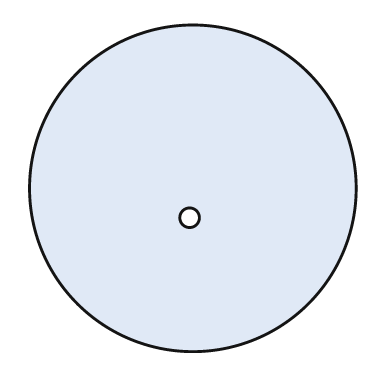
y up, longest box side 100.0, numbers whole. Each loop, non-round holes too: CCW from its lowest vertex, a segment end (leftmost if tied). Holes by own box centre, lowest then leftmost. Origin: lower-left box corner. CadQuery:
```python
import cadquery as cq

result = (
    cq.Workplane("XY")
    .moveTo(50.0, 50.0)
    .circle(50.0)
    .moveTo(49.0, 41.0)
    .circle(3.0)
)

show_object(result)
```